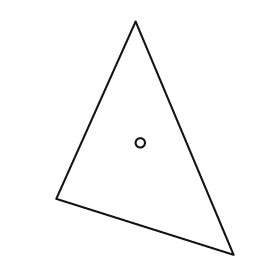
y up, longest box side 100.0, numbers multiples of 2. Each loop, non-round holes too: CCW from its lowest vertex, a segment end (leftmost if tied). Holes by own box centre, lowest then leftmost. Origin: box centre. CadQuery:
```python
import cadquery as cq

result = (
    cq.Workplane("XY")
    .moveTo(38.0, -50.0)
    .lineTo(-4.0, 50.0)
    .lineTo(-38.0, -26.0)
    .close()
    .moveTo(-2.0, -2.0)
    .circle(2.0)
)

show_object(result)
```